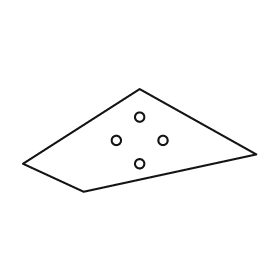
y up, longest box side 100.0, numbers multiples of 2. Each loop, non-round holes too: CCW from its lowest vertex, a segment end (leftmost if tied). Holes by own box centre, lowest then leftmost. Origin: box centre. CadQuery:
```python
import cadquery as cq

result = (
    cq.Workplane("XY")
    .moveTo(-24.0, -22.0)
    .lineTo(50.0, -6.0)
    .lineTo(0.0, 22.0)
    .lineTo(-50.0, -10.0)
    .close()
    .moveTo(0.0, -10.0)
    .circle(2.0)
    .moveTo(-10.0, 0.0)
    .circle(2.0)
    .moveTo(10.0, 0.0)
    .circle(2.0)
    .moveTo(0.0, 10.0)
    .circle(2.0)
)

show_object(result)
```